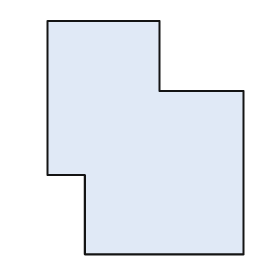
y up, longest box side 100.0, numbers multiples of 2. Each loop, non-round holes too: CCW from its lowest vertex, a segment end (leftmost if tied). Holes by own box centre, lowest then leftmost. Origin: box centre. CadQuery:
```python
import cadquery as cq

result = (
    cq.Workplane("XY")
    .moveTo(-26.0, -50.0)
    .lineTo(42.0, -50.0)
    .lineTo(42.0, 20.0)
    .lineTo(6.0, 20.0)
    .lineTo(6.0, 50.0)
    .lineTo(-42.0, 50.0)
    .lineTo(-42.0, -16.0)
    .lineTo(-26.0, -16.0)
    .close()
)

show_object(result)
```